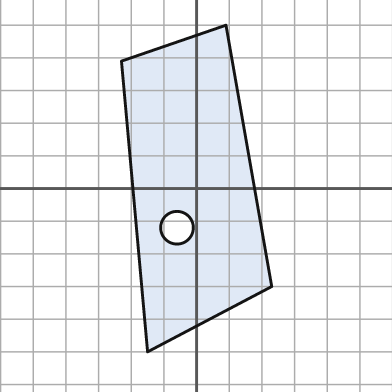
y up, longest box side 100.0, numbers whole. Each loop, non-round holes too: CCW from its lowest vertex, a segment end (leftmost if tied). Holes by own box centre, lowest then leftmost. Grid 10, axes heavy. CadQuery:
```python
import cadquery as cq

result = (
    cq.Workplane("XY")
    .moveTo(-15.0, -50.0)
    .lineTo(23.0, -30.0)
    .lineTo(9.0, 50.0)
    .lineTo(-23.0, 39.0)
    .close()
    .moveTo(-6.0, -12.0)
    .circle(5.0)
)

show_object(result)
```